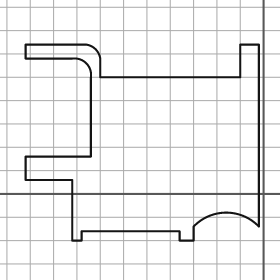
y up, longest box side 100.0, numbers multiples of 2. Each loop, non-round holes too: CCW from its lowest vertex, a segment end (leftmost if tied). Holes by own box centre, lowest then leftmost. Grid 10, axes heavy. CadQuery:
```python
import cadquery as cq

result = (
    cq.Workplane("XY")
    .moveTo(-82.0, -20.0)
    .lineTo(-78.0, -20.0)
    .lineTo(-78.0, -16.0)
    .lineTo(-36.0, -16.0)
    .lineTo(-36.0, -20.0)
    .lineTo(-30.0, -20.0)
    .lineTo(-30.0, -14.0)
    .threePointArc((-16.0, -8.0), (-2.0, -14.0))
    .lineTo(-2.0, 64.0)
    .lineTo(-10.0, 64.0)
    .lineTo(-10.0, 50.0)
    .lineTo(-70.0, 50.0)
    .lineTo(-70.0, 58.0)
    .threePointArc((-72.0, 62.0), (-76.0, 64.0))
    .lineTo(-102.0, 64.0)
    .lineTo(-102.0, 58.0)
    .lineTo(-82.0, 58.0)
    .threePointArc((-76.0, 56.0), (-74.0, 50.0))
    .lineTo(-74.0, 16.0)
    .lineTo(-102.0, 16.0)
    .lineTo(-102.0, 6.0)
    .lineTo(-82.0, 6.0)
    .close()
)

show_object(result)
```